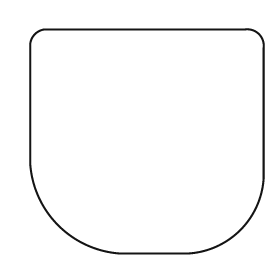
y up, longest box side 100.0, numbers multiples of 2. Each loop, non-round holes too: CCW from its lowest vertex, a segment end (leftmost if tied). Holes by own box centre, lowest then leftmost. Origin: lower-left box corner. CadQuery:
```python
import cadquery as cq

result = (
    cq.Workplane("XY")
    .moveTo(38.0, 0.0)
    .lineTo(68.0, 0.0)
    .threePointArc((90.0, 10.0), (100.0, 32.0))
    .lineTo(100.0, 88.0)
    .threePointArc((98.0, 94.0), (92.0, 96.0))
    .lineTo(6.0, 96.0)
    .threePointArc((2.0, 94.0), (0.0, 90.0))
    .lineTo(0.0, 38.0)
    .threePointArc((12.0, 12.0), (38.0, 0.0))
    .close()
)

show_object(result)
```